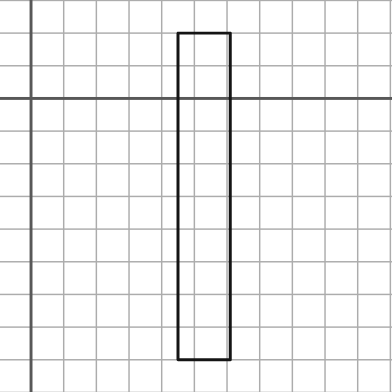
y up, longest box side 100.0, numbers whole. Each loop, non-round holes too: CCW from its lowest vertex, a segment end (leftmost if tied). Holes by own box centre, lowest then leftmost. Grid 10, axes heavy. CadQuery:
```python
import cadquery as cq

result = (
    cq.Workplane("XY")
    .moveTo(45.0, -80.0)
    .lineTo(61.0, -80.0)
    .lineTo(61.0, 20.0)
    .lineTo(45.0, 20.0)
    .close()
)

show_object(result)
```